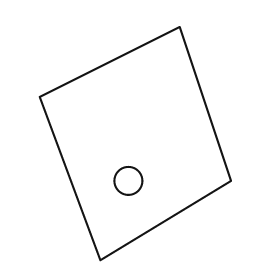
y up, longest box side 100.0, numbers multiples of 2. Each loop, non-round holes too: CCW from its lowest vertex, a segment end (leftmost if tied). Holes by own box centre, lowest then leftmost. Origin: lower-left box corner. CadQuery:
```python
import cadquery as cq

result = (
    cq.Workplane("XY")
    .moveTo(26.0, 0.0)
    .lineTo(82.0, 34.0)
    .lineTo(60.0, 100.0)
    .lineTo(0.0, 70.0)
    .close()
    .moveTo(38.0, 34.0)
    .circle(6.0)
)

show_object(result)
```